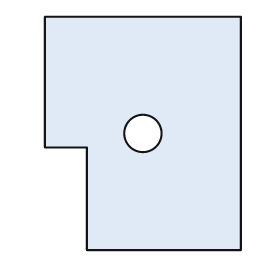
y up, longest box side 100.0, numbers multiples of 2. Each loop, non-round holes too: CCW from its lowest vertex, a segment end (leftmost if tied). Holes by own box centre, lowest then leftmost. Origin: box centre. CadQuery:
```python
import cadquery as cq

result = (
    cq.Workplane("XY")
    .moveTo(-24.0, -50.0)
    .lineTo(42.0, -50.0)
    .lineTo(42.0, 50.0)
    .lineTo(-42.0, 50.0)
    .lineTo(-42.0, -6.0)
    .lineTo(-24.0, -6.0)
    .close()
    .moveTo(0.0, 0.0)
    .circle(8.0)
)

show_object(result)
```